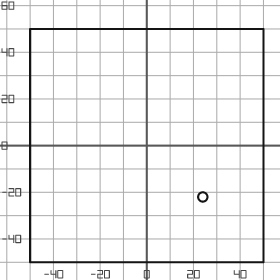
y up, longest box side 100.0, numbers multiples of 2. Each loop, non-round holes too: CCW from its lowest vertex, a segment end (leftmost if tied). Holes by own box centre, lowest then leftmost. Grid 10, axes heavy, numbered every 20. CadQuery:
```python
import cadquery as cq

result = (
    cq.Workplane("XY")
    .moveTo(-50.0, -50.0)
    .lineTo(50.0, -50.0)
    .lineTo(50.0, 50.0)
    .lineTo(-50.0, 50.0)
    .close()
    .moveTo(24.0, -22.0)
    .circle(2.0)
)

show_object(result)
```